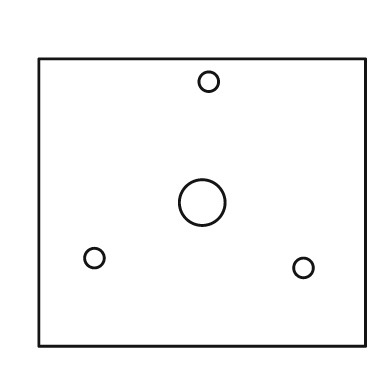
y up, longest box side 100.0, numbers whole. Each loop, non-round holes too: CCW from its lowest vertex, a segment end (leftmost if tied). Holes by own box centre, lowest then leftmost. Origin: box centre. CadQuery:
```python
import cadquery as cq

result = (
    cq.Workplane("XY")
    .moveTo(-50.0, -44.0)
    .lineTo(50.0, -44.0)
    .lineTo(50.0, 44.0)
    .lineTo(-50.0, 44.0)
    .close()
    .moveTo(31.0, -20.0)
    .circle(3.0)
    .moveTo(-33.0, -17.0)
    .circle(3.0)
    .moveTo(0.0, 0.0)
    .circle(7.0)
    .moveTo(2.0, 37.0)
    .circle(3.0)
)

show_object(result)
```